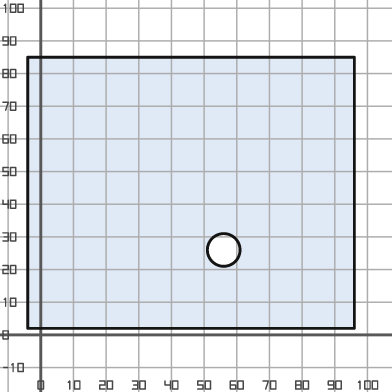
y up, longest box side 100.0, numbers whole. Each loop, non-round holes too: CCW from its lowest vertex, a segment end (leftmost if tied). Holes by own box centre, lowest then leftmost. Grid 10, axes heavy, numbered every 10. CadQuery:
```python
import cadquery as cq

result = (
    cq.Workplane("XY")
    .moveTo(-4.0, 2.0)
    .lineTo(96.0, 2.0)
    .lineTo(96.0, 85.0)
    .lineTo(-4.0, 85.0)
    .close()
    .moveTo(56.0, 26.0)
    .circle(5.0)
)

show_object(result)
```